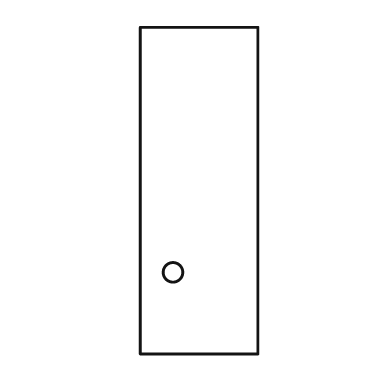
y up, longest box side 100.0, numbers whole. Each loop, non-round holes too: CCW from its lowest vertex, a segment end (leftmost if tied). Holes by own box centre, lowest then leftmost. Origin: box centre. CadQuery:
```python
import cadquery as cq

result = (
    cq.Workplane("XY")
    .moveTo(-18.0, -50.0)
    .lineTo(18.0, -50.0)
    .lineTo(18.0, 50.0)
    .lineTo(-18.0, 50.0)
    .close()
    .moveTo(-8.0, -25.0)
    .circle(3.0)
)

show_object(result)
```